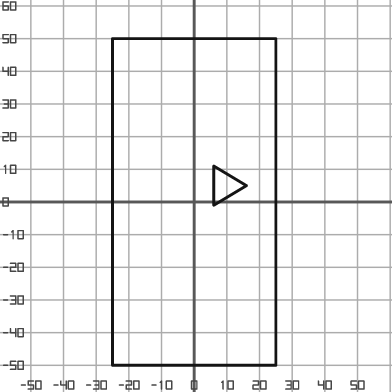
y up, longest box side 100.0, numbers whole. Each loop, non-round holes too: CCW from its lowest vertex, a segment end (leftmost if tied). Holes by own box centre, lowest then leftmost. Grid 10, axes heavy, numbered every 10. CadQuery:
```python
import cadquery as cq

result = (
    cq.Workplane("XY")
    .moveTo(-25.0, -50.0)
    .lineTo(25.0, -50.0)
    .lineTo(25.0, 50.0)
    .lineTo(-25.0, 50.0)
    .close()
    .moveTo(6.0, -1.0)
    .lineTo(16.0, 5.0)
    .lineTo(6.0, 11.0)
    .close()
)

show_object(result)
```